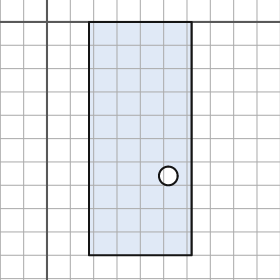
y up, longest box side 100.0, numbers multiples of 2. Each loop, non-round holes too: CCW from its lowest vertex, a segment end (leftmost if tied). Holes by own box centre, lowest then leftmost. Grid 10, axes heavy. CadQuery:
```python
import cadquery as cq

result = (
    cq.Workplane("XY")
    .moveTo(18.0, -100.0)
    .lineTo(62.0, -100.0)
    .lineTo(62.0, 0.0)
    .lineTo(18.0, 0.0)
    .close()
    .moveTo(52.0, -66.0)
    .circle(4.0)
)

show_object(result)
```